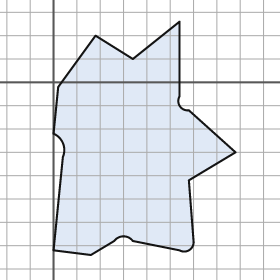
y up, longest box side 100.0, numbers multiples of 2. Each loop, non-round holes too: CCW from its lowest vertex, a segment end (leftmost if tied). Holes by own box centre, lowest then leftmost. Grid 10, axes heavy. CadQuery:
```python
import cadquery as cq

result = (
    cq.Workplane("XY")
    .moveTo(16.0, -74.0)
    .lineTo(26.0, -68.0)
    .threePointArc((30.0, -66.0), (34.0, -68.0))
    .lineTo(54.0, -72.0)
    .threePointArc((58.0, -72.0), (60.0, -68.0))
    .lineTo(58.0, -42.0)
    .lineTo(78.0, -30.0)
    .lineTo(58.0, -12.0)
    .threePointArc((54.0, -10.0), (54.0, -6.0))
    .lineTo(54.0, 26.0)
    .lineTo(34.0, 10.0)
    .lineTo(18.0, 20.0)
    .lineTo(2.0, -2.0)
    .lineTo(0.0, -22.0)
    .threePointArc((4.0, -26.0), (4.0, -32.0))
    .lineTo(0.0, -72.0)
    .close()
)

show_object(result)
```